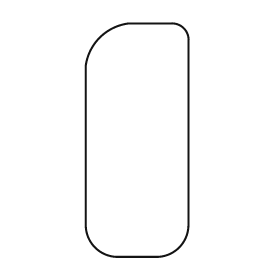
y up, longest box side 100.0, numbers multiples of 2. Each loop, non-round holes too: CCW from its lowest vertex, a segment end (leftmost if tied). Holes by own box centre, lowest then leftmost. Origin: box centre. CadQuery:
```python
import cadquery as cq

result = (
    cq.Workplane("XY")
    .moveTo(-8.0, -50.0)
    .lineTo(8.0, -50.0)
    .threePointArc((18.0, -46.0), (22.0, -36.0))
    .lineTo(22.0, 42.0)
    .threePointArc((20.0, 48.0), (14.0, 50.0))
    .lineTo(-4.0, 50.0)
    .threePointArc((-16.0, 44.0), (-22.0, 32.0))
    .lineTo(-22.0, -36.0)
    .threePointArc((-18.0, -46.0), (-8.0, -50.0))
    .close()
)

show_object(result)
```